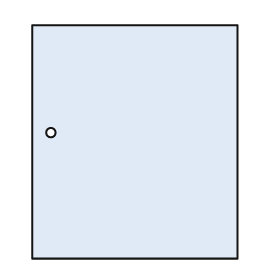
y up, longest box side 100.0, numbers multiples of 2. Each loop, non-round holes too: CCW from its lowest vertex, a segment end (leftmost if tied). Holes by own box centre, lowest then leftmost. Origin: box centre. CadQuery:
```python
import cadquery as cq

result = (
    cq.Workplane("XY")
    .moveTo(-44.0, -50.0)
    .lineTo(44.0, -50.0)
    .lineTo(44.0, 50.0)
    .lineTo(-44.0, 50.0)
    .close()
    .moveTo(-36.0, 4.0)
    .circle(2.0)
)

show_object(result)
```